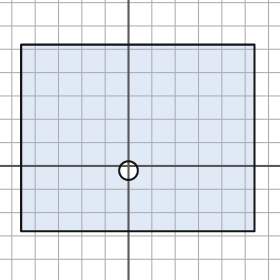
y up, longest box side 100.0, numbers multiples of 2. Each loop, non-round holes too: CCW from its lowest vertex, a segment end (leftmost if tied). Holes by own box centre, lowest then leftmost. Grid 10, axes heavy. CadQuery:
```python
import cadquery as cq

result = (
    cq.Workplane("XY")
    .moveTo(-46.0, -28.0)
    .lineTo(54.0, -28.0)
    .lineTo(54.0, 52.0)
    .lineTo(-46.0, 52.0)
    .close()
    .moveTo(0.0, -2.0)
    .circle(4.0)
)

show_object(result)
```